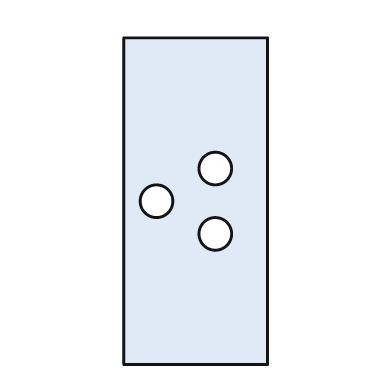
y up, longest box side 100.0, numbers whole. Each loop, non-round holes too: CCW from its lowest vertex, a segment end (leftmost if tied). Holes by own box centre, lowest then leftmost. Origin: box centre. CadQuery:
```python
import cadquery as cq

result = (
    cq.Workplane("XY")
    .moveTo(-22.0, -50.0)
    .lineTo(22.0, -50.0)
    .lineTo(22.0, 50.0)
    .lineTo(-22.0, 50.0)
    .close()
    .moveTo(6.0, -10.0)
    .circle(5.0)
    .moveTo(-12.0, 0.0)
    .circle(5.0)
    .moveTo(6.0, 10.0)
    .circle(5.0)
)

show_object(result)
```